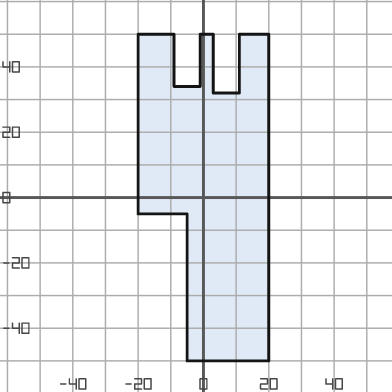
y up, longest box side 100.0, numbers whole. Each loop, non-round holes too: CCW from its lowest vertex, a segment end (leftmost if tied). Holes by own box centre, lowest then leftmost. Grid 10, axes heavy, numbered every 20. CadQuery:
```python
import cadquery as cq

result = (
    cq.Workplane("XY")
    .moveTo(-5.0, -50.0)
    .lineTo(20.0, -50.0)
    .lineTo(20.0, 50.0)
    .lineTo(11.0, 50.0)
    .lineTo(11.0, 32.0)
    .lineTo(3.0, 32.0)
    .lineTo(3.0, 50.0)
    .lineTo(-1.0, 50.0)
    .lineTo(-1.0, 34.0)
    .lineTo(-9.0, 34.0)
    .lineTo(-9.0, 50.0)
    .lineTo(-20.0, 50.0)
    .lineTo(-20.0, -5.0)
    .lineTo(-5.0, -5.0)
    .close()
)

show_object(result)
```